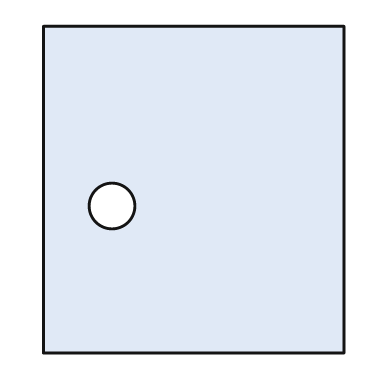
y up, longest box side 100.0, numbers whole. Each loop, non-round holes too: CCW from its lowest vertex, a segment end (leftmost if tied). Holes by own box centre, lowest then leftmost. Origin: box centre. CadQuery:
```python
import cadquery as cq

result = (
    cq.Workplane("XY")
    .moveTo(-46.0, -50.0)
    .lineTo(46.0, -50.0)
    .lineTo(46.0, 50.0)
    .lineTo(-46.0, 50.0)
    .close()
    .moveTo(-25.0, -5.0)
    .circle(7.0)
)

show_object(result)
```